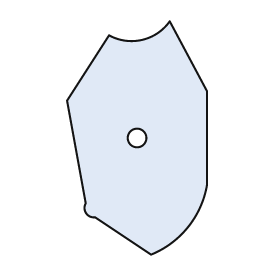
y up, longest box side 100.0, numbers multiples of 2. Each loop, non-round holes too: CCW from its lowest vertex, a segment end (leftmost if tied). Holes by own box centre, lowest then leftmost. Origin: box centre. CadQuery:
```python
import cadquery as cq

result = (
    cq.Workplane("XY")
    .moveTo(6.0, -50.0)
    .threePointArc((22.0, -38.0), (30.0, -20.0))
    .lineTo(30.0, 20.0)
    .lineTo(14.0, 50.0)
    .threePointArc((2.0, 42.0), (-12.0, 44.0))
    .lineTo(-30.0, 16.0)
    .lineTo(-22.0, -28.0)
    .threePointArc((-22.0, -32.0), (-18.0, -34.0))
    .close()
    .moveTo(0.0, 0.0)
    .circle(4.0)
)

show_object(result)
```